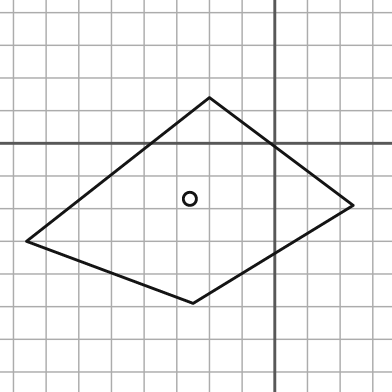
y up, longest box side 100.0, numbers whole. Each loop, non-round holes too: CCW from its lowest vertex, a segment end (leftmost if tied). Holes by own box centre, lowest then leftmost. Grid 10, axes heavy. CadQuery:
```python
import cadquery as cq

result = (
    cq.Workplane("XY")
    .moveTo(-25.0, -49.0)
    .lineTo(24.0, -19.0)
    .lineTo(-20.0, 14.0)
    .lineTo(-76.0, -30.0)
    .close()
    .moveTo(-26.0, -17.0)
    .circle(2.0)
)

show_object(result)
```